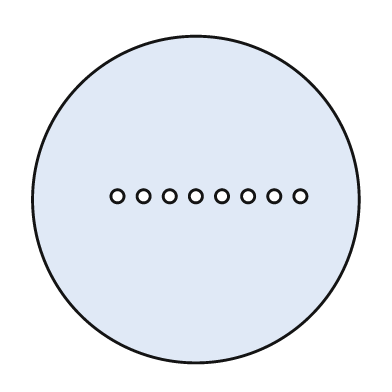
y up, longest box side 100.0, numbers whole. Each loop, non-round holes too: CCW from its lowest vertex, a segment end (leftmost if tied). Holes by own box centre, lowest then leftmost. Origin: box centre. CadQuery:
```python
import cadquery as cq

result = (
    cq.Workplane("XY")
    .moveTo(0.0, 0.0)
    .circle(50.0)
    .moveTo(-24.0, 1.0)
    .circle(2.0)
    .moveTo(-16.0, 1.0)
    .circle(2.0)
    .moveTo(-8.0, 1.0)
    .circle(2.0)
    .moveTo(0.0, 1.0)
    .circle(2.0)
    .moveTo(8.0, 1.0)
    .circle(2.0)
    .moveTo(16.0, 1.0)
    .circle(2.0)
    .moveTo(24.0, 1.0)
    .circle(2.0)
    .moveTo(32.0, 1.0)
    .circle(2.0)
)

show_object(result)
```